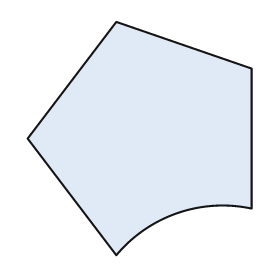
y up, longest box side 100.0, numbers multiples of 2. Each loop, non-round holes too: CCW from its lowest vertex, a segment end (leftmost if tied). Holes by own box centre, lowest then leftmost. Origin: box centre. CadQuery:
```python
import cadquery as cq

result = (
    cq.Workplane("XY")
    .moveTo(-10.0, -50.0)
    .threePointArc((16.0, -32.0), (48.0, -30.0))
    .lineTo(48.0, 30.0)
    .lineTo(-10.0, 50.0)
    .lineTo(-48.0, 0.0)
    .close()
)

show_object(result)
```